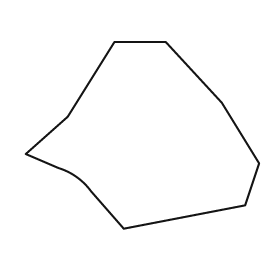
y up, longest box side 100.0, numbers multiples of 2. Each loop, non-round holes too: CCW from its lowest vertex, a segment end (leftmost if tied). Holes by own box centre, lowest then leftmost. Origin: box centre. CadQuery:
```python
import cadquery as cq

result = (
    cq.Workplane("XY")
    .moveTo(-8.0, -40.0)
    .lineTo(44.0, -30.0)
    .lineTo(50.0, -12.0)
    .lineTo(34.0, 14.0)
    .lineTo(10.0, 40.0)
    .lineTo(-12.0, 40.0)
    .lineTo(-32.0, 8.0)
    .lineTo(-50.0, -8.0)
    .lineTo(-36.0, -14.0)
    .threePointArc((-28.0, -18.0), (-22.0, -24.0))
    .close()
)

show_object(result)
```